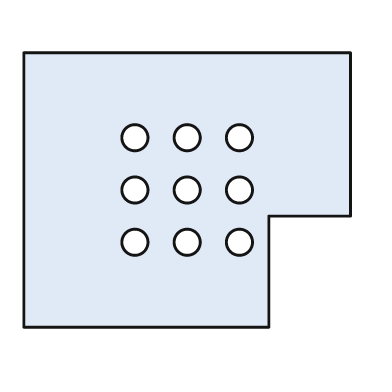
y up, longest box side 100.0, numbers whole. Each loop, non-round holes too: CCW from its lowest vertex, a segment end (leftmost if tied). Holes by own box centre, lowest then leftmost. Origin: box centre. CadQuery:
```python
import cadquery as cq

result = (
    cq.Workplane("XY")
    .moveTo(-50.0, -42.0)
    .lineTo(25.0, -42.0)
    .lineTo(25.0, -8.0)
    .lineTo(50.0, -8.0)
    .lineTo(50.0, 42.0)
    .lineTo(-50.0, 42.0)
    .close()
    .moveTo(-16.0, -16.0)
    .circle(4.0)
    .moveTo(0.0, -16.0)
    .circle(4.0)
    .moveTo(16.0, -16.0)
    .circle(4.0)
    .moveTo(-16.0, 0.0)
    .circle(4.0)
    .moveTo(0.0, 0.0)
    .circle(4.0)
    .moveTo(16.0, 0.0)
    .circle(4.0)
    .moveTo(-16.0, 16.0)
    .circle(4.0)
    .moveTo(0.0, 16.0)
    .circle(4.0)
    .moveTo(16.0, 16.0)
    .circle(4.0)
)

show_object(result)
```